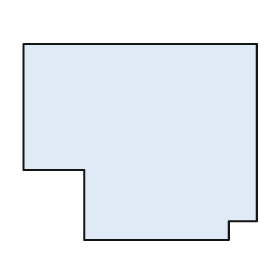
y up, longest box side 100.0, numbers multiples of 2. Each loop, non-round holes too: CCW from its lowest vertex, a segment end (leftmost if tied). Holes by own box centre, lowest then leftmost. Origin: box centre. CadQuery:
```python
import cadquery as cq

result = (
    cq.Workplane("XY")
    .moveTo(-24.0, -42.0)
    .lineTo(38.0, -42.0)
    .lineTo(38.0, -34.0)
    .lineTo(50.0, -34.0)
    .lineTo(50.0, 42.0)
    .lineTo(-50.0, 42.0)
    .lineTo(-50.0, -12.0)
    .lineTo(-24.0, -12.0)
    .close()
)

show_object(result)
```